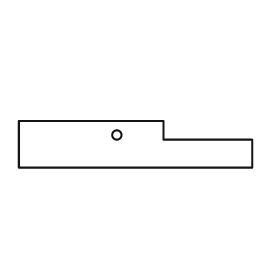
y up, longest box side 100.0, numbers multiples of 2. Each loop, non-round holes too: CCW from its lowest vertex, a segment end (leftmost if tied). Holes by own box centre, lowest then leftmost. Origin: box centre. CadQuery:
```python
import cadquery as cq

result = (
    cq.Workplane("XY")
    .moveTo(-50.0, -10.0)
    .lineTo(50.0, -10.0)
    .lineTo(50.0, 2.0)
    .lineTo(12.0, 2.0)
    .lineTo(12.0, 10.0)
    .lineTo(-50.0, 10.0)
    .close()
    .moveTo(-8.0, 4.0)
    .circle(2.0)
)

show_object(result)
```